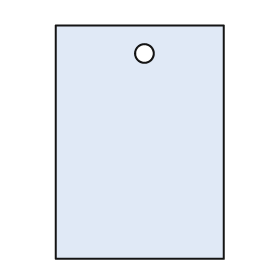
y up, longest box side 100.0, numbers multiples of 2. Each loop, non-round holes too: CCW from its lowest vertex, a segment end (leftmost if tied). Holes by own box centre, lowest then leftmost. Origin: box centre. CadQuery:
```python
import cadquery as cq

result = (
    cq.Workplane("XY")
    .moveTo(-36.0, -50.0)
    .lineTo(36.0, -50.0)
    .lineTo(36.0, 50.0)
    .lineTo(-36.0, 50.0)
    .close()
    .moveTo(2.0, 38.0)
    .circle(4.0)
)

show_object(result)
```